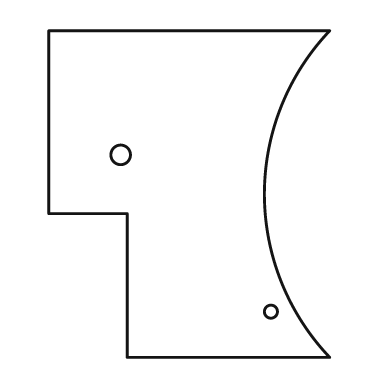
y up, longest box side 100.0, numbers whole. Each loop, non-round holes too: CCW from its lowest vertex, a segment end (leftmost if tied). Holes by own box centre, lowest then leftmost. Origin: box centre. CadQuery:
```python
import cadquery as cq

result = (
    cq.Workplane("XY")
    .moveTo(-19.0, -50.0)
    .lineTo(43.0, -50.0)
    .threePointArc((23.0, 0.0), (43.0, 50.0))
    .lineTo(-43.0, 50.0)
    .lineTo(-43.0, -6.0)
    .lineTo(-19.0, -6.0)
    .close()
    .moveTo(25.0, -36.0)
    .circle(2.0)
    .moveTo(-21.0, 12.0)
    .circle(3.0)
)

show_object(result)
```